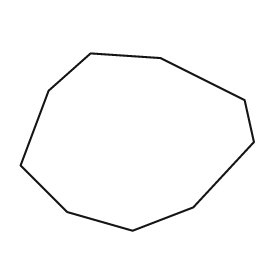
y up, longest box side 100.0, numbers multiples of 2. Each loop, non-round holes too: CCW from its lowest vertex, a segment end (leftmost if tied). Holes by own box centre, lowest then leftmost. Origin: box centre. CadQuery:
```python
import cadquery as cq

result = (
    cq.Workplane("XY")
    .moveTo(-2.0, -38.0)
    .lineTo(24.0, -28.0)
    .lineTo(50.0, 0.0)
    .lineTo(46.0, 18.0)
    .lineTo(10.0, 36.0)
    .lineTo(-20.0, 38.0)
    .lineTo(-38.0, 22.0)
    .lineTo(-50.0, -10.0)
    .lineTo(-30.0, -30.0)
    .close()
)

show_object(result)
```